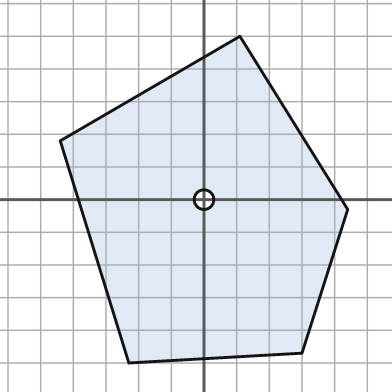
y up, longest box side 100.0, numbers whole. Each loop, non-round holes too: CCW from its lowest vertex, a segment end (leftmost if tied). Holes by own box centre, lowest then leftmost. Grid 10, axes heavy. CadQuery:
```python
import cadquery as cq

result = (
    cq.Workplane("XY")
    .moveTo(-23.0, -50.0)
    .lineTo(30.0, -47.0)
    .lineTo(44.0, -3.0)
    .lineTo(11.0, 50.0)
    .lineTo(-44.0, 18.0)
    .close()
    .moveTo(0.0, 0.0)
    .circle(3.0)
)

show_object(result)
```